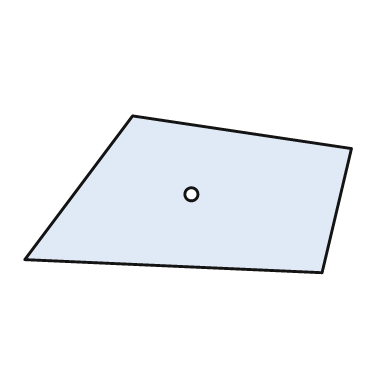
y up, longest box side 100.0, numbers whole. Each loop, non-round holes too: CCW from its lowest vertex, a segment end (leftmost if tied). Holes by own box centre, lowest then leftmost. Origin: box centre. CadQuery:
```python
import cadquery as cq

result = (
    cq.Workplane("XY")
    .moveTo(41.0, -24.0)
    .lineTo(50.0, 14.0)
    .lineTo(-17.0, 24.0)
    .lineTo(-50.0, -20.0)
    .close()
    .moveTo(1.0, 0.0)
    .circle(2.0)
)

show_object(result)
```